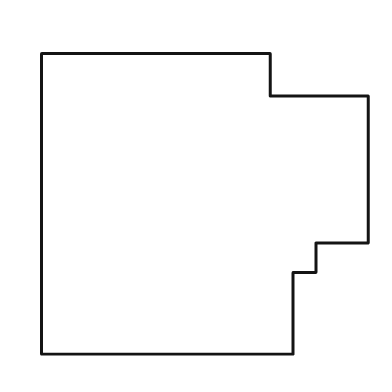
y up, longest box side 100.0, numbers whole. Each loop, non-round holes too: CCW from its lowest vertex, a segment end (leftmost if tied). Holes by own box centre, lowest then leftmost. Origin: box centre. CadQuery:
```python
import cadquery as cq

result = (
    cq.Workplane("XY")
    .moveTo(-50.0, -46.0)
    .lineTo(27.0, -46.0)
    .lineTo(27.0, -21.0)
    .lineTo(34.0, -21.0)
    .lineTo(34.0, -12.0)
    .lineTo(50.0, -12.0)
    .lineTo(50.0, 33.0)
    .lineTo(20.0, 33.0)
    .lineTo(20.0, 46.0)
    .lineTo(-50.0, 46.0)
    .close()
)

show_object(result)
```